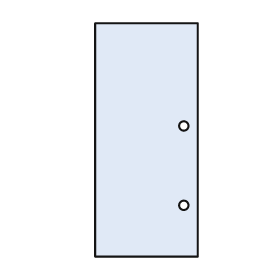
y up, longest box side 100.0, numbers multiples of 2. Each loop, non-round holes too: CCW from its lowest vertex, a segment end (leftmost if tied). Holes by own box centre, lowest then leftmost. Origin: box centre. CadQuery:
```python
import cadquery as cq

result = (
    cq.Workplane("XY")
    .moveTo(-22.0, -50.0)
    .lineTo(22.0, -50.0)
    .lineTo(22.0, 50.0)
    .lineTo(-22.0, 50.0)
    .close()
    .moveTo(16.0, -28.0)
    .circle(2.0)
    .moveTo(16.0, 6.0)
    .circle(2.0)
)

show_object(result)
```